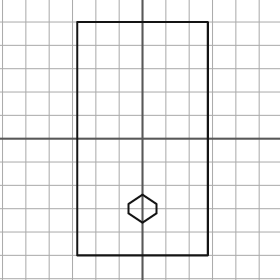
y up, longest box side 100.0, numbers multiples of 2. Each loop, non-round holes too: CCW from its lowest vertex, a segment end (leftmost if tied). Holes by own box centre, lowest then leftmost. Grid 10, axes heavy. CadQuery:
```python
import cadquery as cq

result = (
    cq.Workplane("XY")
    .moveTo(-28.0, -50.0)
    .lineTo(28.0, -50.0)
    .lineTo(28.0, 50.0)
    .lineTo(-28.0, 50.0)
    .close()
    .moveTo(0.0, -36.0)
    .lineTo(6.0, -32.0)
    .lineTo(6.0, -28.0)
    .lineTo(0.0, -24.0)
    .lineTo(-6.0, -28.0)
    .lineTo(-6.0, -32.0)
    .close()
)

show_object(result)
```